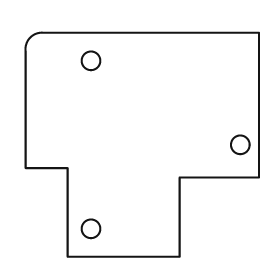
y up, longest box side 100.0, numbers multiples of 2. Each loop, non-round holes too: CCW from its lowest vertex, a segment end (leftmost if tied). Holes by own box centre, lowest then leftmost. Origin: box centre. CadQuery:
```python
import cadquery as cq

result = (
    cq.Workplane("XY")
    .moveTo(-32.0, -48.0)
    .lineTo(16.0, -48.0)
    .lineTo(16.0, -14.0)
    .lineTo(50.0, -14.0)
    .lineTo(50.0, 48.0)
    .lineTo(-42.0, 48.0)
    .threePointArc((-48.0, 46.0), (-50.0, 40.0))
    .lineTo(-50.0, -10.0)
    .lineTo(-32.0, -10.0)
    .close()
    .moveTo(-22.0, -36.0)
    .circle(4.0)
    .moveTo(42.0, 0.0)
    .circle(4.0)
    .moveTo(-22.0, 36.0)
    .circle(4.0)
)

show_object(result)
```